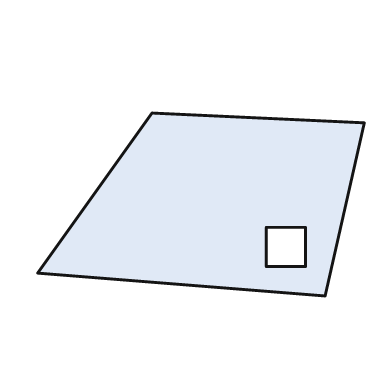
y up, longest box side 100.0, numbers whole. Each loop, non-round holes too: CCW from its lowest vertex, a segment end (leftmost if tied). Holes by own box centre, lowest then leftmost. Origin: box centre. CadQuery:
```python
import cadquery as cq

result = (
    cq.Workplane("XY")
    .moveTo(38.0, -28.0)
    .lineTo(50.0, 25.0)
    .lineTo(-15.0, 28.0)
    .lineTo(-50.0, -21.0)
    .close()
    .moveTo(20.0, -19.0)
    .lineTo(32.0, -19.0)
    .lineTo(32.0, -7.0)
    .lineTo(20.0, -7.0)
    .close()
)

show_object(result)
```